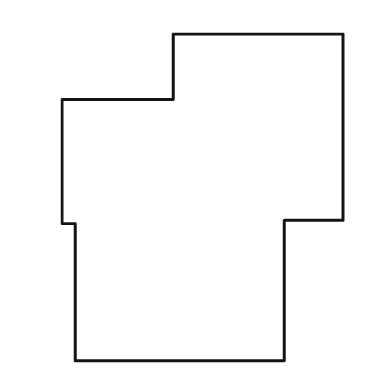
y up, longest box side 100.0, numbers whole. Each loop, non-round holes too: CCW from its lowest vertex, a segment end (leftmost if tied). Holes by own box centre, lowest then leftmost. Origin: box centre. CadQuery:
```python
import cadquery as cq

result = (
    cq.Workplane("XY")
    .moveTo(-39.0, -50.0)
    .lineTo(25.0, -50.0)
    .lineTo(25.0, -7.0)
    .lineTo(43.0, -7.0)
    .lineTo(43.0, 50.0)
    .lineTo(-9.0, 50.0)
    .lineTo(-9.0, 30.0)
    .lineTo(-43.0, 30.0)
    .lineTo(-43.0, -8.0)
    .lineTo(-39.0, -8.0)
    .close()
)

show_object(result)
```